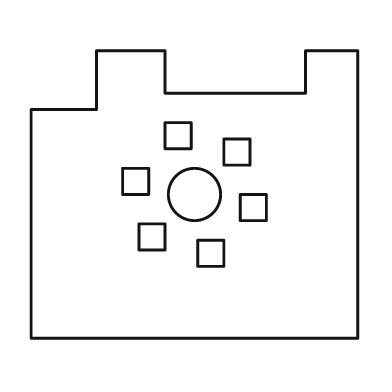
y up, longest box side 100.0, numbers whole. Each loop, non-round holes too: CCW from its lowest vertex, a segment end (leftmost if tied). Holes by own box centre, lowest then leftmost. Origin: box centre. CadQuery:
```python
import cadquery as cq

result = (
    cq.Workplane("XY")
    .moveTo(-50.0, -44.0)
    .lineTo(50.0, -44.0)
    .lineTo(50.0, 44.0)
    .lineTo(34.0, 44.0)
    .lineTo(34.0, 31.0)
    .lineTo(-9.0, 31.0)
    .lineTo(-9.0, 44.0)
    .lineTo(-30.0, 44.0)
    .lineTo(-30.0, 26.0)
    .lineTo(-50.0, 26.0)
    .close()
    .moveTo(1.0, -22.0)
    .lineTo(9.0, -22.0)
    .lineTo(9.0, -14.0)
    .lineTo(1.0, -14.0)
    .close()
    .moveTo(-17.0, -17.0)
    .lineTo(-9.0, -17.0)
    .lineTo(-9.0, -9.0)
    .lineTo(-17.0, -9.0)
    .close()
    .moveTo(14.0, -8.0)
    .lineTo(22.0, -8.0)
    .lineTo(22.0, 0.0)
    .lineTo(14.0, 0.0)
    .close()
    .moveTo(0.0, 0.0)
    .circle(8.0)
    .moveTo(-22.0, 0.0)
    .lineTo(-14.0, 0.0)
    .lineTo(-14.0, 8.0)
    .lineTo(-22.0, 8.0)
    .close()
    .moveTo(9.0, 9.0)
    .lineTo(17.0, 9.0)
    .lineTo(17.0, 17.0)
    .lineTo(9.0, 17.0)
    .close()
    .moveTo(-9.0, 14.0)
    .lineTo(-1.0, 14.0)
    .lineTo(-1.0, 22.0)
    .lineTo(-9.0, 22.0)
    .close()
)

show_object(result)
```